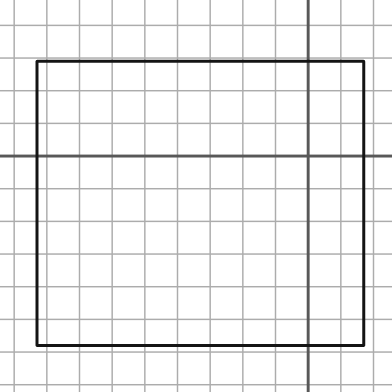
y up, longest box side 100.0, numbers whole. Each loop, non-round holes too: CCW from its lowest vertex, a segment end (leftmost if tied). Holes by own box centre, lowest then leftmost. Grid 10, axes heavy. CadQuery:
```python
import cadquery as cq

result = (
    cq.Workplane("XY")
    .moveTo(-83.0, -58.0)
    .lineTo(17.0, -58.0)
    .lineTo(17.0, 29.0)
    .lineTo(-83.0, 29.0)
    .close()
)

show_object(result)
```